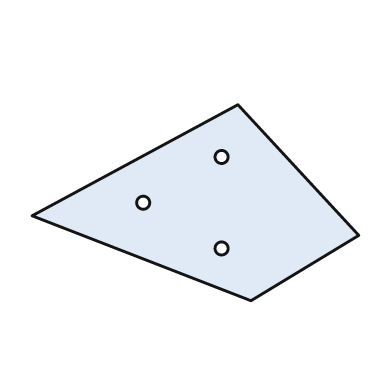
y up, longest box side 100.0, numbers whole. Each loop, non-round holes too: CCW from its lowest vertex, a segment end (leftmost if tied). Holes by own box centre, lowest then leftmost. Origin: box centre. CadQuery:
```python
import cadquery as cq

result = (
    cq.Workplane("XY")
    .moveTo(17.0, -30.0)
    .lineTo(50.0, -10.0)
    .lineTo(13.0, 30.0)
    .lineTo(-50.0, -4.0)
    .close()
    .moveTo(8.0, -14.0)
    .circle(2.0)
    .moveTo(-16.0, 0.0)
    .circle(2.0)
    .moveTo(8.0, 14.0)
    .circle(2.0)
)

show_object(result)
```